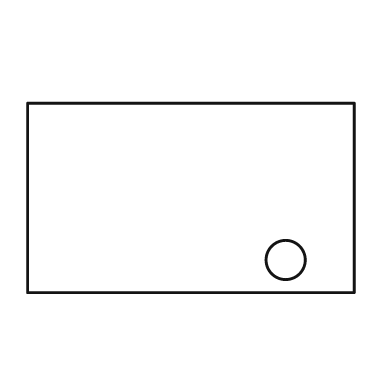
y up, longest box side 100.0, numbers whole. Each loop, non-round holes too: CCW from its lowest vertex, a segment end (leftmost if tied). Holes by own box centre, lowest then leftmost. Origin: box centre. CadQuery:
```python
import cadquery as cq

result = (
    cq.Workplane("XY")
    .moveTo(-50.0, -29.0)
    .lineTo(50.0, -29.0)
    .lineTo(50.0, 29.0)
    .lineTo(-50.0, 29.0)
    .close()
    .moveTo(29.0, -19.0)
    .circle(6.0)
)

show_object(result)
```